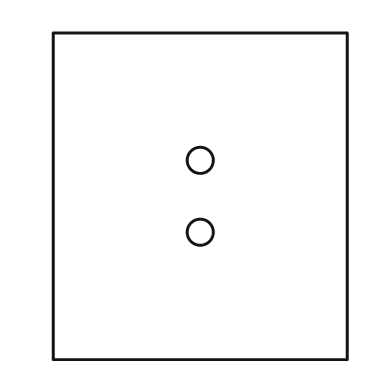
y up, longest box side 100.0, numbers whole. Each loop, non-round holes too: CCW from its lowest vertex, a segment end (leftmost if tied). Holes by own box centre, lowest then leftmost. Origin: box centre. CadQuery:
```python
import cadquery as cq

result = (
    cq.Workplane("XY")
    .moveTo(-45.0, -50.0)
    .lineTo(45.0, -50.0)
    .lineTo(45.0, 50.0)
    .lineTo(-45.0, 50.0)
    .close()
    .moveTo(0.0, -11.0)
    .circle(4.0)
    .moveTo(0.0, 11.0)
    .circle(4.0)
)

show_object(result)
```